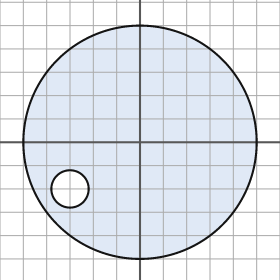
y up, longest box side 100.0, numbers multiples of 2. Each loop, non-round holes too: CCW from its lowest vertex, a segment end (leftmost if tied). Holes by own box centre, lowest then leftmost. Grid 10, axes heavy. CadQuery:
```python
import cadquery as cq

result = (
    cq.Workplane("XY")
    .moveTo(0.0, 0.0)
    .circle(50.0)
    .moveTo(-30.0, -20.0)
    .circle(8.0)
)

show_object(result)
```